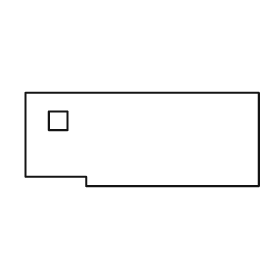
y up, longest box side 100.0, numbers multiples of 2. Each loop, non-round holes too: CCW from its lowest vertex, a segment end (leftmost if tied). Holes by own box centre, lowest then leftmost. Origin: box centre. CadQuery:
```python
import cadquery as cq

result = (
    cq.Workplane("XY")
    .moveTo(-24.0, -20.0)
    .lineTo(50.0, -20.0)
    .lineTo(50.0, 20.0)
    .lineTo(-50.0, 20.0)
    .lineTo(-50.0, -16.0)
    .lineTo(-24.0, -16.0)
    .close()
    .moveTo(-40.0, 4.0)
    .lineTo(-32.0, 4.0)
    .lineTo(-32.0, 12.0)
    .lineTo(-40.0, 12.0)
    .close()
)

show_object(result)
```